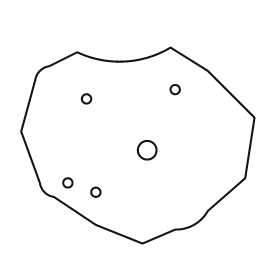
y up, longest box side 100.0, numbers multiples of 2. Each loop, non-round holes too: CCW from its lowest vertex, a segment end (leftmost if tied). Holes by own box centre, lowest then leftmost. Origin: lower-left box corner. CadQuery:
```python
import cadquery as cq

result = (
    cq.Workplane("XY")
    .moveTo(52.0, 0.0)
    .lineTo(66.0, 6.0)
    .threePointArc((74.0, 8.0), (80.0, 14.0))
    .lineTo(96.0, 28.0)
    .lineTo(100.0, 54.0)
    .lineTo(80.0, 74.0)
    .lineTo(64.0, 84.0)
    .threePointArc((44.0, 78.0), (24.0, 82.0))
    .lineTo(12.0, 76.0)
    .threePointArc((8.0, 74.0), (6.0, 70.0))
    .lineTo(0.0, 48.0)
    .lineTo(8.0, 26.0)
    .threePointArc((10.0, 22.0), (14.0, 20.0))
    .lineTo(32.0, 8.0)
    .close()
    .moveTo(32.0, 22.0)
    .circle(2.0)
    .moveTo(20.0, 26.0)
    .circle(2.0)
    .moveTo(54.0, 40.0)
    .circle(4.0)
    .moveTo(28.0, 62.0)
    .circle(2.0)
    .moveTo(66.0, 66.0)
    .circle(2.0)
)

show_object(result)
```